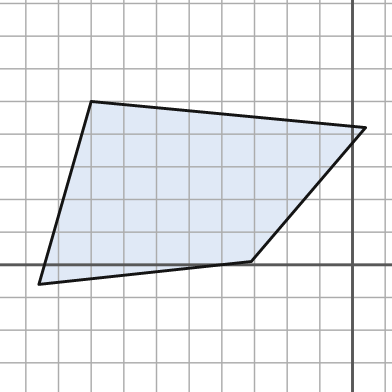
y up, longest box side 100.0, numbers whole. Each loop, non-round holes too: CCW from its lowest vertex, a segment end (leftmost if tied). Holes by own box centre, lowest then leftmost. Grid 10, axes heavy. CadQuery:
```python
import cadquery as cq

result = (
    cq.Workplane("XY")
    .moveTo(-96.0, -6.0)
    .lineTo(-31.0, 1.0)
    .lineTo(4.0, 42.0)
    .lineTo(-80.0, 50.0)
    .close()
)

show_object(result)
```